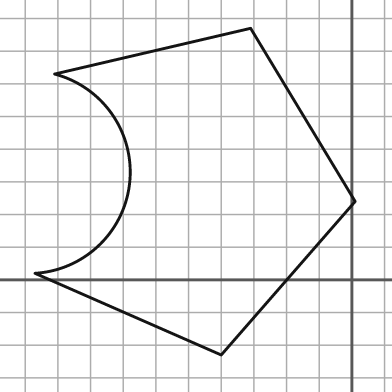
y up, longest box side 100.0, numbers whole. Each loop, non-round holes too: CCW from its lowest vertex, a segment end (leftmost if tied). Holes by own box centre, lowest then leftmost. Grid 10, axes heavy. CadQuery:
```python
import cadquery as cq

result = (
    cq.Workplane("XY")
    .moveTo(-40.0, -23.0)
    .lineTo(1.0, 24.0)
    .lineTo(-31.0, 77.0)
    .lineTo(-91.0, 63.0)
    .threePointArc((-68.0, 30.0), (-97.0, 2.0))
    .close()
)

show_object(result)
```